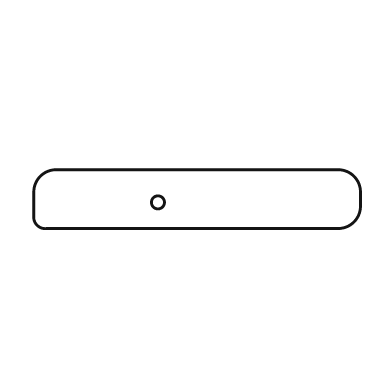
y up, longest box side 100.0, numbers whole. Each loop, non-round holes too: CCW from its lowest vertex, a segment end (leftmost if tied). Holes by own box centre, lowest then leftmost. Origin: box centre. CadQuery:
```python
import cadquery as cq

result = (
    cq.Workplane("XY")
    .moveTo(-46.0, -9.0)
    .lineTo(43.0, -9.0)
    .threePointArc((48.0, -7.0), (50.0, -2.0))
    .lineTo(50.0, 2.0)
    .threePointArc((48.0, 7.0), (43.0, 9.0))
    .lineTo(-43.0, 9.0)
    .threePointArc((-48.0, 7.0), (-50.0, 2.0))
    .lineTo(-50.0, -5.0)
    .threePointArc((-49.0, -8.0), (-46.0, -9.0))
    .close()
    .moveTo(-12.0, -1.0)
    .circle(2.0)
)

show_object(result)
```